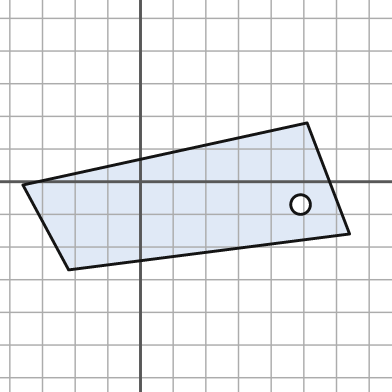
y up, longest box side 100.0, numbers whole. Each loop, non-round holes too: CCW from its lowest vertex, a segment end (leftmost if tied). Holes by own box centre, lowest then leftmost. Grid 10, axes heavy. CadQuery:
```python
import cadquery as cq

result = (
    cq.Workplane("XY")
    .moveTo(-22.0, -27.0)
    .lineTo(64.0, -16.0)
    .lineTo(51.0, 18.0)
    .lineTo(-36.0, -1.0)
    .close()
    .moveTo(49.0, -7.0)
    .circle(3.0)
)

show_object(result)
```